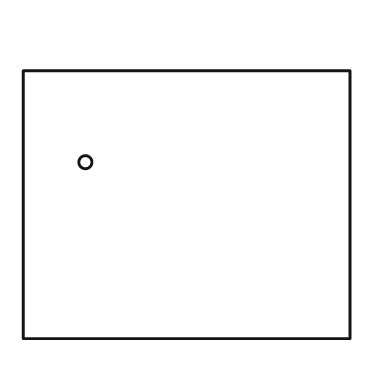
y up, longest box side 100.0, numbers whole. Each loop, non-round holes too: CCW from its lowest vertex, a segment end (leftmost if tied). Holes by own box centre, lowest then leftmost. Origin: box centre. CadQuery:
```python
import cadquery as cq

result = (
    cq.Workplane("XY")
    .moveTo(-50.0, -41.0)
    .lineTo(50.0, -41.0)
    .lineTo(50.0, 41.0)
    .lineTo(-50.0, 41.0)
    .close()
    .moveTo(-31.0, 13.0)
    .circle(2.0)
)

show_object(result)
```